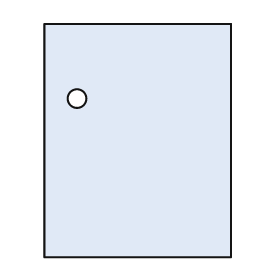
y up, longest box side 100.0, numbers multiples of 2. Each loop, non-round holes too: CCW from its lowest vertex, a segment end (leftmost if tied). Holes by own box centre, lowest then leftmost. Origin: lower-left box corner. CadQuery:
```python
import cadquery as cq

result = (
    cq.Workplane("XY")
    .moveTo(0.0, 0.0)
    .lineTo(80.0, 0.0)
    .lineTo(80.0, 100.0)
    .lineTo(0.0, 100.0)
    .close()
    .moveTo(14.0, 68.0)
    .circle(4.0)
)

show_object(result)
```